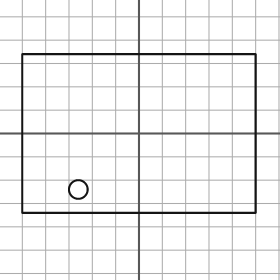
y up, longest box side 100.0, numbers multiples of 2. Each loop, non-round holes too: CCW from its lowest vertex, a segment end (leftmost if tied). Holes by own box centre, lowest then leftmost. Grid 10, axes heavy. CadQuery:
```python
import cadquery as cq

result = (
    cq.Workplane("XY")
    .moveTo(-50.0, -34.0)
    .lineTo(50.0, -34.0)
    .lineTo(50.0, 34.0)
    .lineTo(-50.0, 34.0)
    .close()
    .moveTo(-26.0, -24.0)
    .circle(4.0)
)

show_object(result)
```